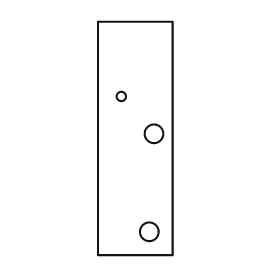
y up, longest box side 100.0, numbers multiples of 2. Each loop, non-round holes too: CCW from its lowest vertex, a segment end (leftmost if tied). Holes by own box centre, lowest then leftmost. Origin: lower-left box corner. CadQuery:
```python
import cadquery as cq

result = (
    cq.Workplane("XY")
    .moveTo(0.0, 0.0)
    .lineTo(32.0, 0.0)
    .lineTo(32.0, 100.0)
    .lineTo(0.0, 100.0)
    .close()
    .moveTo(22.0, 10.0)
    .circle(4.0)
    .moveTo(24.0, 52.0)
    .circle(4.0)
    .moveTo(10.0, 68.0)
    .circle(2.0)
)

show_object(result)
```